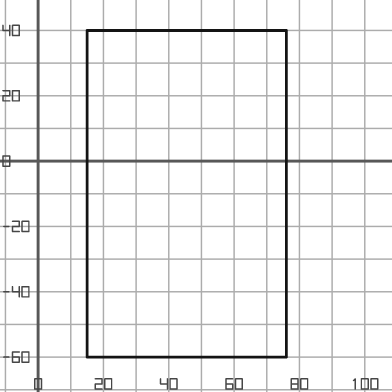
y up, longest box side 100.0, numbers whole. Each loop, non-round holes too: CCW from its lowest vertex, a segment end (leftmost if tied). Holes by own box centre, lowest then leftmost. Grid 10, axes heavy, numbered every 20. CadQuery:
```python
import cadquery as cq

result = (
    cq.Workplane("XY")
    .moveTo(15.0, -60.0)
    .lineTo(76.0, -60.0)
    .lineTo(76.0, 40.0)
    .lineTo(15.0, 40.0)
    .close()
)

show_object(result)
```